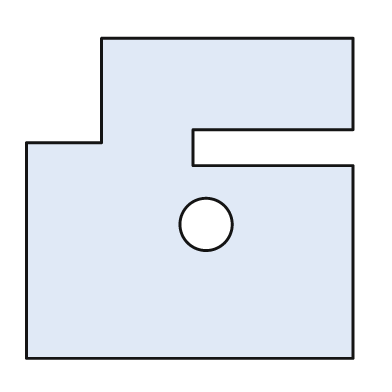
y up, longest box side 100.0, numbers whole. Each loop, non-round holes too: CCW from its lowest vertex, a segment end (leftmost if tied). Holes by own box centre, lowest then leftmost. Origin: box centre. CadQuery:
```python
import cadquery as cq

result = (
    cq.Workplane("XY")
    .moveTo(-50.0, -49.0)
    .lineTo(50.0, -49.0)
    .lineTo(50.0, 10.0)
    .lineTo(1.0, 10.0)
    .lineTo(1.0, 21.0)
    .lineTo(50.0, 21.0)
    .lineTo(50.0, 49.0)
    .lineTo(-27.0, 49.0)
    .lineTo(-27.0, 17.0)
    .lineTo(-50.0, 17.0)
    .close()
    .moveTo(5.0, -8.0)
    .circle(8.0)
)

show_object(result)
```